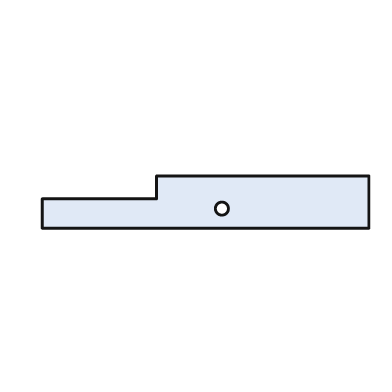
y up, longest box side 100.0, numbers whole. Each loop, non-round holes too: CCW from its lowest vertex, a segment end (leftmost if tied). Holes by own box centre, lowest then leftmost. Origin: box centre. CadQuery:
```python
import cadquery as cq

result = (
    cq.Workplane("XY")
    .moveTo(-50.0, -8.0)
    .lineTo(50.0, -8.0)
    .lineTo(50.0, 8.0)
    .lineTo(-15.0, 8.0)
    .lineTo(-15.0, 1.0)
    .lineTo(-50.0, 1.0)
    .close()
    .moveTo(5.0, -2.0)
    .circle(2.0)
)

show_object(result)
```